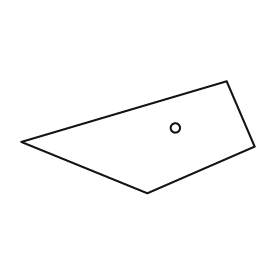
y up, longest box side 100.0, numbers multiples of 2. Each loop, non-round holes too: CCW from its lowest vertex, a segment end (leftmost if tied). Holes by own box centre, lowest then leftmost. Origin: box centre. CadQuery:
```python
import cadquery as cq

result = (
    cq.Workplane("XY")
    .moveTo(4.0, -24.0)
    .lineTo(50.0, -4.0)
    .lineTo(38.0, 24.0)
    .lineTo(-50.0, -2.0)
    .close()
    .moveTo(16.0, 4.0)
    .circle(2.0)
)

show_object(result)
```